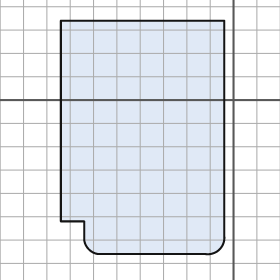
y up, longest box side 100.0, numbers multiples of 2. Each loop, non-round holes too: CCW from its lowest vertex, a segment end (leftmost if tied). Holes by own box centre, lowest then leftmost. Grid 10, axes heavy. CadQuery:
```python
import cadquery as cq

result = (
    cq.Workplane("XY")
    .moveTo(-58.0, -66.0)
    .lineTo(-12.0, -66.0)
    .threePointArc((-6.0, -64.0), (-4.0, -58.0))
    .lineTo(-4.0, 34.0)
    .lineTo(-74.0, 34.0)
    .lineTo(-74.0, -52.0)
    .lineTo(-64.0, -52.0)
    .lineTo(-64.0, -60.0)
    .threePointArc((-62.0, -64.0), (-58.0, -66.0))
    .close()
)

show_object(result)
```